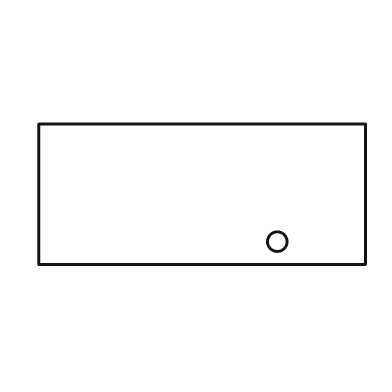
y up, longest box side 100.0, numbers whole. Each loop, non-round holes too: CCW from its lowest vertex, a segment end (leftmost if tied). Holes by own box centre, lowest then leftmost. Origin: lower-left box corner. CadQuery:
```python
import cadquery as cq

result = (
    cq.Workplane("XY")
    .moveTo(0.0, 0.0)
    .lineTo(100.0, 0.0)
    .lineTo(100.0, 43.0)
    .lineTo(0.0, 43.0)
    .close()
    .moveTo(73.0, 7.0)
    .circle(3.0)
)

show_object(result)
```